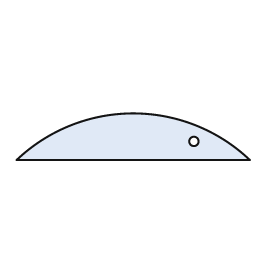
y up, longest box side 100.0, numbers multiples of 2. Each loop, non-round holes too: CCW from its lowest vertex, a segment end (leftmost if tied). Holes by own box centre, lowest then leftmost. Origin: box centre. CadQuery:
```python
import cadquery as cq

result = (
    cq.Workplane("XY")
    .moveTo(-50.0, -10.0)
    .lineTo(50.0, -10.0)
    .threePointArc((0.0, 10.0), (-50.0, -10.0))
    .close()
    .moveTo(26.0, -2.0)
    .circle(2.0)
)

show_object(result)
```